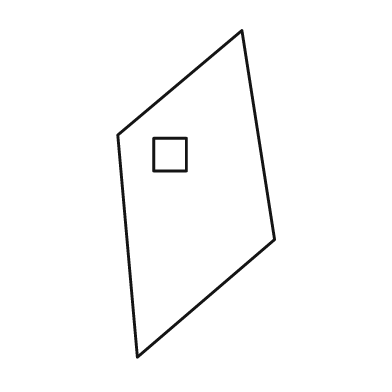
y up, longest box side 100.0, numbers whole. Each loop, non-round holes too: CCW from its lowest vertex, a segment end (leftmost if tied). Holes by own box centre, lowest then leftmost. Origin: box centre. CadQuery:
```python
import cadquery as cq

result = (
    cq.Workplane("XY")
    .moveTo(-18.0, -50.0)
    .lineTo(24.0, -14.0)
    .lineTo(14.0, 50.0)
    .lineTo(-24.0, 18.0)
    .close()
    .moveTo(-13.0, 7.0)
    .lineTo(-3.0, 7.0)
    .lineTo(-3.0, 17.0)
    .lineTo(-13.0, 17.0)
    .close()
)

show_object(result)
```